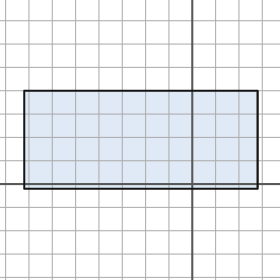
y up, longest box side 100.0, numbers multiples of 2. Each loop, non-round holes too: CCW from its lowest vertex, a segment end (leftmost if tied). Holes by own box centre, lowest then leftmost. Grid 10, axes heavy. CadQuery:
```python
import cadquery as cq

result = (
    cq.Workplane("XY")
    .moveTo(-72.0, -2.0)
    .lineTo(28.0, -2.0)
    .lineTo(28.0, 40.0)
    .lineTo(-72.0, 40.0)
    .close()
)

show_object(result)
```